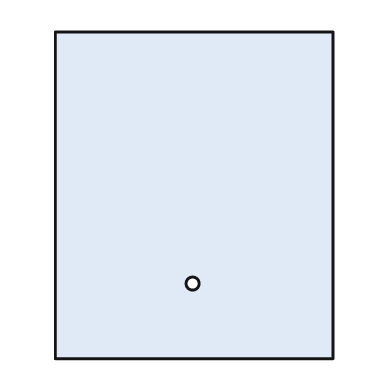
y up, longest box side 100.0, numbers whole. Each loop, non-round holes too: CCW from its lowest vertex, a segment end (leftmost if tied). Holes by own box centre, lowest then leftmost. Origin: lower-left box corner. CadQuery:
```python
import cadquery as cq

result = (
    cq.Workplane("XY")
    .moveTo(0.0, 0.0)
    .lineTo(85.0, 0.0)
    .lineTo(85.0, 100.0)
    .lineTo(0.0, 100.0)
    .close()
    .moveTo(42.0, 23.0)
    .circle(2.0)
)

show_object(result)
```